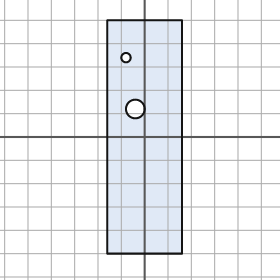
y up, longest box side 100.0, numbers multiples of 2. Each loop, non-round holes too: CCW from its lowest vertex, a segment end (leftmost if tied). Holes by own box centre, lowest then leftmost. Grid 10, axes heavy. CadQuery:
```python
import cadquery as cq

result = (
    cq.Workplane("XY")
    .moveTo(-16.0, -50.0)
    .lineTo(16.0, -50.0)
    .lineTo(16.0, 50.0)
    .lineTo(-16.0, 50.0)
    .close()
    .moveTo(-4.0, 12.0)
    .circle(4.0)
    .moveTo(-8.0, 34.0)
    .circle(2.0)
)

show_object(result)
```